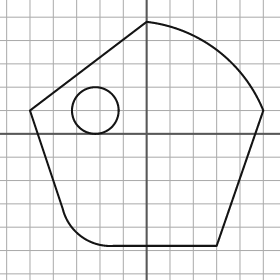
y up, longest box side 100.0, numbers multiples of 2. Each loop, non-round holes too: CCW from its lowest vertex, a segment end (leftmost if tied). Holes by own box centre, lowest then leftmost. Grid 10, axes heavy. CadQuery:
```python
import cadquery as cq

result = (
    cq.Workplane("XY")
    .moveTo(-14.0, -48.0)
    .lineTo(30.0, -48.0)
    .lineTo(50.0, 10.0)
    .threePointArc((30.0, 36.0), (0.0, 48.0))
    .lineTo(-50.0, 10.0)
    .lineTo(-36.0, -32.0)
    .threePointArc((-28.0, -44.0), (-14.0, -48.0))
    .close()
    .moveTo(-22.0, 10.0)
    .circle(10.0)
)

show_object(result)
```